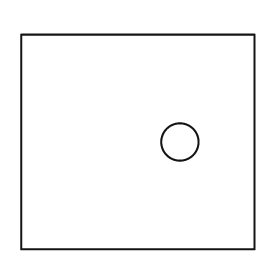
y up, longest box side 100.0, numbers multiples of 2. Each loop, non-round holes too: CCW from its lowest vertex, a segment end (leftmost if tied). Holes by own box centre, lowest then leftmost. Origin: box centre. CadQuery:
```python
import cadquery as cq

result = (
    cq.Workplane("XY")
    .moveTo(-50.0, -46.0)
    .lineTo(50.0, -46.0)
    .lineTo(50.0, 46.0)
    .lineTo(-50.0, 46.0)
    .close()
    .moveTo(18.0, 0.0)
    .circle(8.0)
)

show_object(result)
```